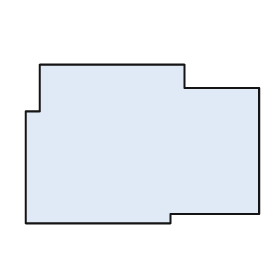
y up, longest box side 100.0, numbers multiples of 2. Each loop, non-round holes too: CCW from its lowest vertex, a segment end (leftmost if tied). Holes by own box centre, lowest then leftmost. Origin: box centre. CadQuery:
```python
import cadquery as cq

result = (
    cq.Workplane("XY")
    .moveTo(-50.0, -34.0)
    .lineTo(12.0, -34.0)
    .lineTo(12.0, -30.0)
    .lineTo(50.0, -30.0)
    .lineTo(50.0, 24.0)
    .lineTo(18.0, 24.0)
    .lineTo(18.0, 34.0)
    .lineTo(-44.0, 34.0)
    .lineTo(-44.0, 14.0)
    .lineTo(-50.0, 14.0)
    .close()
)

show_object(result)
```